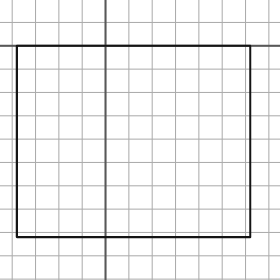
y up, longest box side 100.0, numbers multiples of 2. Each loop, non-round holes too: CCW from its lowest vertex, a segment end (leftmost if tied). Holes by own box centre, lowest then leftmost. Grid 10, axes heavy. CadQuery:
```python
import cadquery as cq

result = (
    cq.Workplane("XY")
    .moveTo(-38.0, -82.0)
    .lineTo(62.0, -82.0)
    .lineTo(62.0, 0.0)
    .lineTo(-38.0, 0.0)
    .close()
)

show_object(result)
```